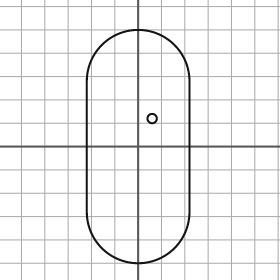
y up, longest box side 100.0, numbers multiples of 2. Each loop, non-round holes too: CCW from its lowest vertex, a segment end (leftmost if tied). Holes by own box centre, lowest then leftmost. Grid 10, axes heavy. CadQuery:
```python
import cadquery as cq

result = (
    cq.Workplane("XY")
    .moveTo(-22.0, -28.0)
    .threePointArc((0.0, -50.0), (22.0, -28.0))
    .lineTo(22.0, 28.0)
    .threePointArc((0.0, 50.0), (-22.0, 28.0))
    .close()
    .moveTo(6.0, 12.0)
    .circle(2.0)
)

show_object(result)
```